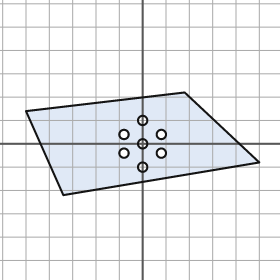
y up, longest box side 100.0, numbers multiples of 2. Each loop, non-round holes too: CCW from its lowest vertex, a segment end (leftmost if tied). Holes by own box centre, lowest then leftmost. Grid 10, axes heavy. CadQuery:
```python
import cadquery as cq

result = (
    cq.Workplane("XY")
    .moveTo(-34.0, -22.0)
    .lineTo(50.0, -8.0)
    .lineTo(18.0, 22.0)
    .lineTo(-50.0, 14.0)
    .close()
    .moveTo(0.0, -10.0)
    .circle(2.0)
    .moveTo(-8.0, -4.0)
    .circle(2.0)
    .moveTo(8.0, -4.0)
    .circle(2.0)
    .moveTo(0.0, 0.0)
    .circle(2.0)
    .moveTo(-8.0, 4.0)
    .circle(2.0)
    .moveTo(8.0, 4.0)
    .circle(2.0)
    .moveTo(0.0, 10.0)
    .circle(2.0)
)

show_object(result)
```